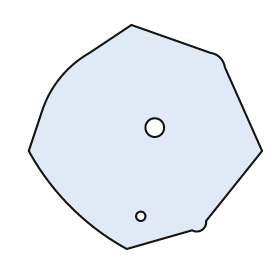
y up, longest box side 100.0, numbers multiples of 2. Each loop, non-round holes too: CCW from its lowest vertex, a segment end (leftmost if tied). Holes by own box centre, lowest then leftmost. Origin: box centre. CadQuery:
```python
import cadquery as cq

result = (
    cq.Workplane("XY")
    .moveTo(-8.0, -48.0)
    .lineTo(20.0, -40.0)
    .threePointArc((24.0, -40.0), (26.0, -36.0))
    .lineTo(50.0, -6.0)
    .lineTo(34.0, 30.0)
    .threePointArc((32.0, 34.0), (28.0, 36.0))
    .lineTo(-6.0, 48.0)
    .lineTo(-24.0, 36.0)
    .threePointArc((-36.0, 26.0), (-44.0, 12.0))
    .lineTo(-50.0, -6.0)
    .threePointArc((-32.0, -30.0), (-8.0, -48.0))
    .close()
    .moveTo(-2.0, -34.0)
    .circle(2.0)
    .moveTo(4.0, 4.0)
    .circle(4.0)
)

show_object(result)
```